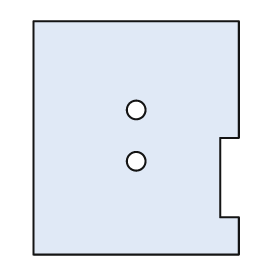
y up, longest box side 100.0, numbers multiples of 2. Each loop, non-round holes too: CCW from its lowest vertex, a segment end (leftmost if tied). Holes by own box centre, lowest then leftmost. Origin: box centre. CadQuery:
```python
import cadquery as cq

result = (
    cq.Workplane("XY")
    .moveTo(-44.0, -50.0)
    .lineTo(44.0, -50.0)
    .lineTo(44.0, -34.0)
    .lineTo(36.0, -34.0)
    .lineTo(36.0, 0.0)
    .lineTo(44.0, 0.0)
    .lineTo(44.0, 50.0)
    .lineTo(-44.0, 50.0)
    .close()
    .moveTo(0.0, -10.0)
    .circle(4.0)
    .moveTo(0.0, 12.0)
    .circle(4.0)
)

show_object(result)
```